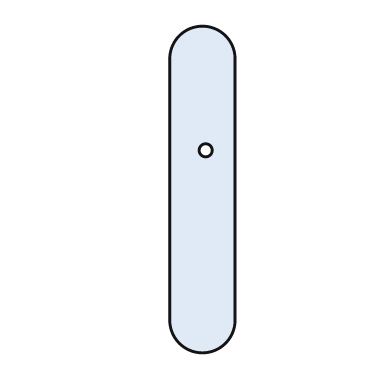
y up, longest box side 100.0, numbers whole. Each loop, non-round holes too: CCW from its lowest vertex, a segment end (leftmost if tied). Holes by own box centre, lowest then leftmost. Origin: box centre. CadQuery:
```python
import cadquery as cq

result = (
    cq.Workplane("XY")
    .moveTo(-10.0, -40.0)
    .threePointArc((0.0, -50.0), (10.0, -40.0))
    .lineTo(10.0, 40.0)
    .threePointArc((0.0, 50.0), (-10.0, 40.0))
    .close()
    .moveTo(1.0, 12.0)
    .circle(2.0)
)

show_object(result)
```